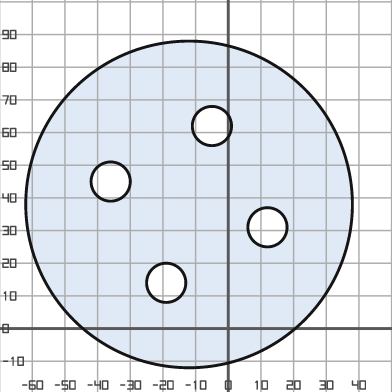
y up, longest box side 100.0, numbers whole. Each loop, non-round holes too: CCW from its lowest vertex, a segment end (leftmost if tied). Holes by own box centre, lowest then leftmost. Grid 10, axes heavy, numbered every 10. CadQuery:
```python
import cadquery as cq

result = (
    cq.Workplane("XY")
    .moveTo(-12.0, 38.0)
    .circle(50.0)
    .moveTo(-19.0, 14.0)
    .circle(6.0)
    .moveTo(12.0, 31.0)
    .circle(6.0)
    .moveTo(-36.0, 45.0)
    .circle(6.0)
    .moveTo(-5.0, 62.0)
    .circle(6.0)
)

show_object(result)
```